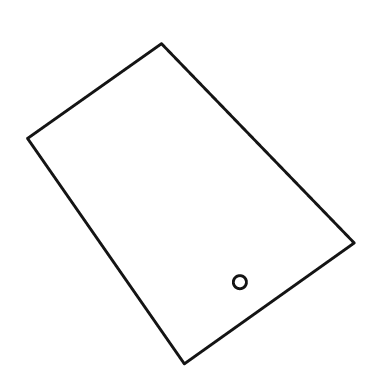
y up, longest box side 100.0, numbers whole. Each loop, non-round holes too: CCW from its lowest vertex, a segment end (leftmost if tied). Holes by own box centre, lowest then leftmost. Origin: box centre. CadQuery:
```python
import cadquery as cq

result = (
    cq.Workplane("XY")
    .moveTo(-2.0, -49.0)
    .lineTo(50.0, -12.0)
    .lineTo(-9.0, 49.0)
    .lineTo(-50.0, 20.0)
    .close()
    .moveTo(15.0, -24.0)
    .circle(2.0)
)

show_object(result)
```